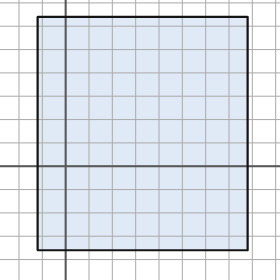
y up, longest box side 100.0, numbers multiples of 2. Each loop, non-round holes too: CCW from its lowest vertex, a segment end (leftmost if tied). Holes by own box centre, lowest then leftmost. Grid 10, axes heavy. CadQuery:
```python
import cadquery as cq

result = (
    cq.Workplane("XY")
    .moveTo(-12.0, -36.0)
    .lineTo(78.0, -36.0)
    .lineTo(78.0, 64.0)
    .lineTo(-12.0, 64.0)
    .close()
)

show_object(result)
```